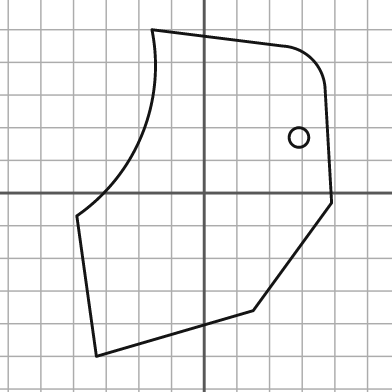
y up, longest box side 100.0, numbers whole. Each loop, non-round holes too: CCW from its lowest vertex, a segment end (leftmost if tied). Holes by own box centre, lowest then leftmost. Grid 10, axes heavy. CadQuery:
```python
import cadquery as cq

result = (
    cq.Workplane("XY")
    .moveTo(-33.0, -50.0)
    .lineTo(15.0, -36.0)
    .lineTo(39.0, -3.0)
    .lineTo(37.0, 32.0)
    .threePointArc((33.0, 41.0), (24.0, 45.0))
    .lineTo(-16.0, 50.0)
    .threePointArc((-19.0, 18.0), (-39.0, -7.0))
    .close()
    .moveTo(29.0, 17.0)
    .circle(3.0)
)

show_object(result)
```